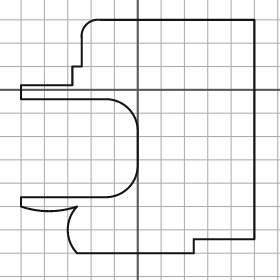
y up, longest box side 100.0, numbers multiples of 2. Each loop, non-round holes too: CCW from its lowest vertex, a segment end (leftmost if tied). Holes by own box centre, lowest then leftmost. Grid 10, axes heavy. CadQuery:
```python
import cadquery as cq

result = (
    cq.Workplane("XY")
    .moveTo(-26.0, -70.0)
    .lineTo(24.0, -70.0)
    .lineTo(24.0, -64.0)
    .lineTo(50.0, -64.0)
    .lineTo(50.0, 30.0)
    .lineTo(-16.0, 30.0)
    .threePointArc((-22.0, 28.0), (-24.0, 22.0))
    .lineTo(-24.0, 10.0)
    .lineTo(-28.0, 10.0)
    .lineTo(-28.0, 2.0)
    .lineTo(-50.0, 2.0)
    .lineTo(-50.0, -4.0)
    .lineTo(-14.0, -4.0)
    .threePointArc((-4.0, -8.0), (0.0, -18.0))
    .lineTo(0.0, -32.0)
    .threePointArc((-4.0, -42.0), (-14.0, -46.0))
    .lineTo(-50.0, -46.0)
    .lineTo(-50.0, -50.0)
    .threePointArc((-38.0, -52.0), (-26.0, -50.0))
    .threePointArc((-30.0, -60.0), (-26.0, -70.0))
    .close()
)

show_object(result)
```